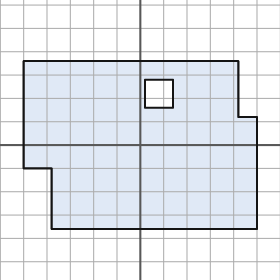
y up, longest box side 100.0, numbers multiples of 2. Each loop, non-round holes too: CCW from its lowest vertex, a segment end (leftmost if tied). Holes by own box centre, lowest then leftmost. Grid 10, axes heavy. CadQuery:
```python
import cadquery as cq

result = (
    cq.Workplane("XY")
    .moveTo(-38.0, -36.0)
    .lineTo(50.0, -36.0)
    .lineTo(50.0, 12.0)
    .lineTo(42.0, 12.0)
    .lineTo(42.0, 36.0)
    .lineTo(-50.0, 36.0)
    .lineTo(-50.0, -10.0)
    .lineTo(-38.0, -10.0)
    .close()
    .moveTo(2.0, 16.0)
    .lineTo(14.0, 16.0)
    .lineTo(14.0, 28.0)
    .lineTo(2.0, 28.0)
    .close()
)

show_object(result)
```